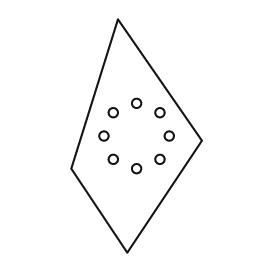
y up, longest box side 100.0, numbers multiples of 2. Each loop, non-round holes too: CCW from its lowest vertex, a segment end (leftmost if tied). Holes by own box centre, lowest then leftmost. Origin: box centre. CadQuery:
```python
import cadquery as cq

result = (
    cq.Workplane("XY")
    .moveTo(-4.0, -50.0)
    .lineTo(28.0, -2.0)
    .lineTo(-8.0, 50.0)
    .lineTo(-28.0, -14.0)
    .close()
    .moveTo(0.0, -14.0)
    .circle(2.0)
    .moveTo(-10.0, -10.0)
    .circle(2.0)
    .moveTo(10.0, -10.0)
    .circle(2.0)
    .moveTo(-14.0, 0.0)
    .circle(2.0)
    .moveTo(14.0, 0.0)
    .circle(2.0)
    .moveTo(-10.0, 10.0)
    .circle(2.0)
    .moveTo(10.0, 10.0)
    .circle(2.0)
    .moveTo(0.0, 14.0)
    .circle(2.0)
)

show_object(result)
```